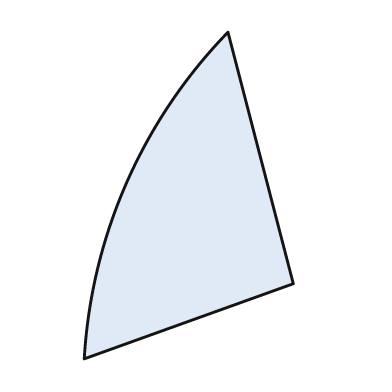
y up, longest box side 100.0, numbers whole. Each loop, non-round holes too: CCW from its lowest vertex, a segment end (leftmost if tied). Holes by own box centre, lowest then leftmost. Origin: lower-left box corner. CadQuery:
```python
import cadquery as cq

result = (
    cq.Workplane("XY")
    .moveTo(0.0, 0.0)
    .lineTo(64.0, 23.0)
    .lineTo(44.0, 100.0)
    .threePointArc((13.0, 54.0), (0.0, 0.0))
    .close()
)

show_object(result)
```